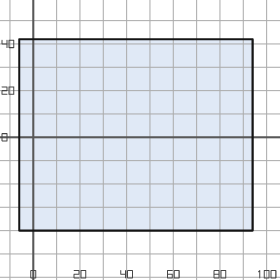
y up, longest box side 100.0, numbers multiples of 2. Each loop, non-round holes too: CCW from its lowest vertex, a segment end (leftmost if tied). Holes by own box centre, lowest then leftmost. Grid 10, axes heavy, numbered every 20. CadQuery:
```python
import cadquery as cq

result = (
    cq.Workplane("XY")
    .moveTo(-6.0, -40.0)
    .lineTo(94.0, -40.0)
    .lineTo(94.0, 42.0)
    .lineTo(-6.0, 42.0)
    .close()
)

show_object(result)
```